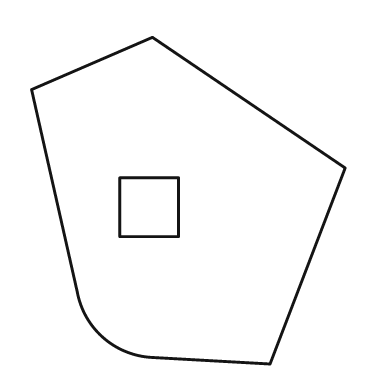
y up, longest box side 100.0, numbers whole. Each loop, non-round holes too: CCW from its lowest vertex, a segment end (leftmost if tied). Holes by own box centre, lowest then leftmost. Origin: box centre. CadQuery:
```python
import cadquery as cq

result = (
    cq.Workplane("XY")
    .moveTo(25.0, -50.0)
    .lineTo(48.0, 10.0)
    .lineTo(-11.0, 50.0)
    .lineTo(-48.0, 34.0)
    .lineTo(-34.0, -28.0)
    .threePointArc((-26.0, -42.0), (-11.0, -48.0))
    .close()
    .moveTo(-21.0, -11.0)
    .lineTo(-3.0, -11.0)
    .lineTo(-3.0, 7.0)
    .lineTo(-21.0, 7.0)
    .close()
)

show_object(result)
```